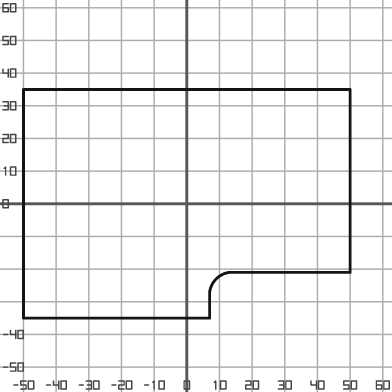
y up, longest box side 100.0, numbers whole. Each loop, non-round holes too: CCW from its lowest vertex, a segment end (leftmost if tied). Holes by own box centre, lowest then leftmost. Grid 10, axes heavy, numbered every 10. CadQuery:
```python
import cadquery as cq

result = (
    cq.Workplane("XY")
    .moveTo(-50.0, -35.0)
    .lineTo(7.0, -35.0)
    .lineTo(7.0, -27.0)
    .threePointArc((9.0, -23.0), (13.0, -21.0))
    .lineTo(50.0, -21.0)
    .lineTo(50.0, 35.0)
    .lineTo(-50.0, 35.0)
    .close()
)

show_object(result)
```